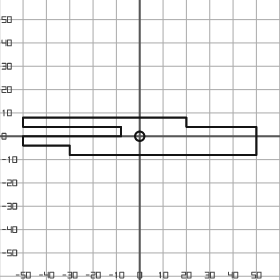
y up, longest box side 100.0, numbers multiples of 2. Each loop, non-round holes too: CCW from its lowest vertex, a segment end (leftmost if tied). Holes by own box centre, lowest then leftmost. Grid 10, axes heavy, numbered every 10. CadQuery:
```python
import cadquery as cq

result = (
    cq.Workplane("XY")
    .moveTo(-30.0, -8.0)
    .lineTo(50.0, -8.0)
    .lineTo(50.0, 4.0)
    .lineTo(20.0, 4.0)
    .lineTo(20.0, 8.0)
    .lineTo(-50.0, 8.0)
    .lineTo(-50.0, 4.0)
    .lineTo(-8.0, 4.0)
    .lineTo(-8.0, 0.0)
    .lineTo(-50.0, 0.0)
    .lineTo(-50.0, -4.0)
    .lineTo(-30.0, -4.0)
    .close()
    .moveTo(0.0, 0.0)
    .circle(2.0)
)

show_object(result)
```